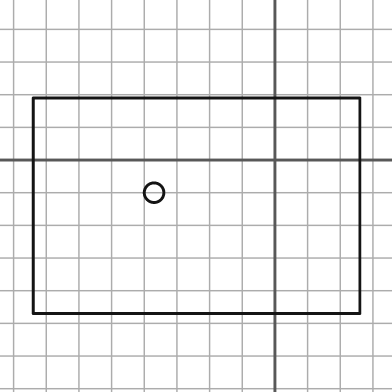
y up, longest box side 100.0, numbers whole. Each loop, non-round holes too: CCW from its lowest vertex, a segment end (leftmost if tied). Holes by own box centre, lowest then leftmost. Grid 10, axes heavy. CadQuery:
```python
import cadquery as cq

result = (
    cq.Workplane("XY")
    .moveTo(-74.0, -47.0)
    .lineTo(26.0, -47.0)
    .lineTo(26.0, 19.0)
    .lineTo(-74.0, 19.0)
    .close()
    .moveTo(-37.0, -10.0)
    .circle(3.0)
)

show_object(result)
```